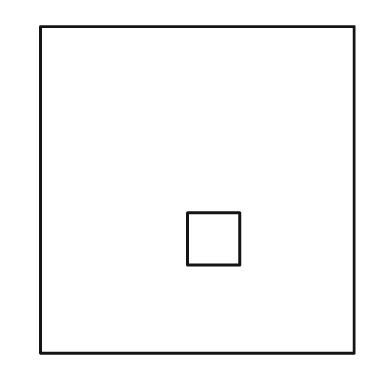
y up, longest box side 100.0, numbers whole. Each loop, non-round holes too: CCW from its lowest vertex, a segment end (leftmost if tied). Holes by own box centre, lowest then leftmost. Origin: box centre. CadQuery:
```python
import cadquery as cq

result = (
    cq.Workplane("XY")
    .moveTo(-48.0, -50.0)
    .lineTo(48.0, -50.0)
    .lineTo(48.0, 50.0)
    .lineTo(-48.0, 50.0)
    .close()
    .moveTo(-3.0, -23.0)
    .lineTo(13.0, -23.0)
    .lineTo(13.0, -7.0)
    .lineTo(-3.0, -7.0)
    .close()
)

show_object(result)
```